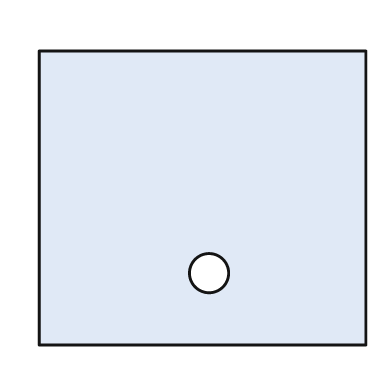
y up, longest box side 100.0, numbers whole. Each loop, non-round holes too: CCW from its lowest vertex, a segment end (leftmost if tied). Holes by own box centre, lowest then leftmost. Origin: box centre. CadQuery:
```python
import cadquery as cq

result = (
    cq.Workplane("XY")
    .moveTo(-50.0, -45.0)
    .lineTo(50.0, -45.0)
    .lineTo(50.0, 45.0)
    .lineTo(-50.0, 45.0)
    .close()
    .moveTo(2.0, -23.0)
    .circle(6.0)
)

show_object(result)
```